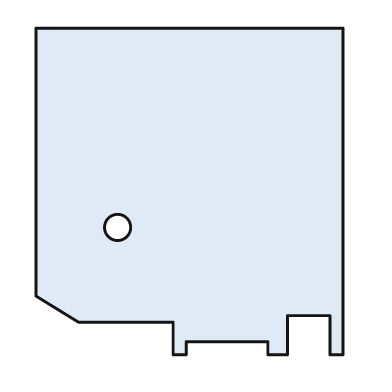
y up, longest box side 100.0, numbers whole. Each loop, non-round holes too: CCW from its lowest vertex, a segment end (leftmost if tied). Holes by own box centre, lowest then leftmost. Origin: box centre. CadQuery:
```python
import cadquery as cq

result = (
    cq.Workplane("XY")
    .moveTo(-5.0, -50.0)
    .lineTo(-1.0, -50.0)
    .lineTo(-1.0, -46.0)
    .lineTo(24.0, -46.0)
    .lineTo(24.0, -50.0)
    .lineTo(30.0, -50.0)
    .lineTo(30.0, -38.0)
    .lineTo(43.0, -38.0)
    .lineTo(43.0, -50.0)
    .lineTo(47.0, -50.0)
    .lineTo(47.0, 50.0)
    .lineTo(-47.0, 50.0)
    .lineTo(-47.0, -32.0)
    .lineTo(-34.0, -40.0)
    .lineTo(-5.0, -40.0)
    .close()
    .moveTo(-22.0, -11.0)
    .circle(4.0)
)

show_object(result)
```